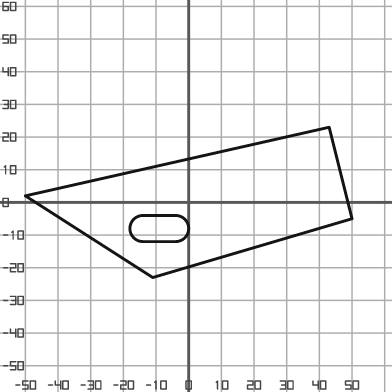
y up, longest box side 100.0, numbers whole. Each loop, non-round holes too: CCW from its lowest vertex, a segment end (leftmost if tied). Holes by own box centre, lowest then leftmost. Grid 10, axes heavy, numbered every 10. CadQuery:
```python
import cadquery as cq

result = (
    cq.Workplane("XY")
    .moveTo(-11.0, -23.0)
    .lineTo(50.0, -5.0)
    .lineTo(43.0, 23.0)
    .lineTo(-50.0, 2.0)
    .close()
    .moveTo(-14.0, -12.0)
    .lineTo(-4.0, -12.0)
    .threePointArc((0.0, -8.0), (-4.0, -4.0))
    .lineTo(-14.0, -4.0)
    .threePointArc((-18.0, -8.0), (-14.0, -12.0))
    .close()
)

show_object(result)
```